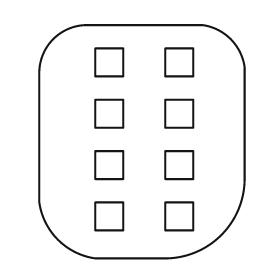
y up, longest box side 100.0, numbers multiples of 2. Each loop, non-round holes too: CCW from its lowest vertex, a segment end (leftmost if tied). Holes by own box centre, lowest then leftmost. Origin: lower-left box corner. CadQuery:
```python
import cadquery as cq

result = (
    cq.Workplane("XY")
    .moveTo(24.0, 0.0)
    .lineTo(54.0, 0.0)
    .threePointArc((78.0, 10.0), (88.0, 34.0))
    .lineTo(88.0, 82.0)
    .threePointArc((82.0, 94.0), (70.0, 100.0))
    .lineTo(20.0, 100.0)
    .threePointArc((6.0, 94.0), (0.0, 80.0))
    .lineTo(0.0, 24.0)
    .threePointArc((8.0, 8.0), (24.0, 0.0))
    .close()
    .moveTo(24.0, 12.0)
    .lineTo(36.0, 12.0)
    .lineTo(36.0, 24.0)
    .lineTo(24.0, 24.0)
    .close()
    .moveTo(54.0, 12.0)
    .lineTo(66.0, 12.0)
    .lineTo(66.0, 24.0)
    .lineTo(54.0, 24.0)
    .close()
    .moveTo(24.0, 34.0)
    .lineTo(36.0, 34.0)
    .lineTo(36.0, 46.0)
    .lineTo(24.0, 46.0)
    .close()
    .moveTo(54.0, 34.0)
    .lineTo(66.0, 34.0)
    .lineTo(66.0, 46.0)
    .lineTo(54.0, 46.0)
    .close()
    .moveTo(24.0, 56.0)
    .lineTo(36.0, 56.0)
    .lineTo(36.0, 68.0)
    .lineTo(24.0, 68.0)
    .close()
    .moveTo(54.0, 56.0)
    .lineTo(66.0, 56.0)
    .lineTo(66.0, 68.0)
    .lineTo(54.0, 68.0)
    .close()
    .moveTo(24.0, 78.0)
    .lineTo(36.0, 78.0)
    .lineTo(36.0, 90.0)
    .lineTo(24.0, 90.0)
    .close()
    .moveTo(54.0, 78.0)
    .lineTo(66.0, 78.0)
    .lineTo(66.0, 90.0)
    .lineTo(54.0, 90.0)
    .close()
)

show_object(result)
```